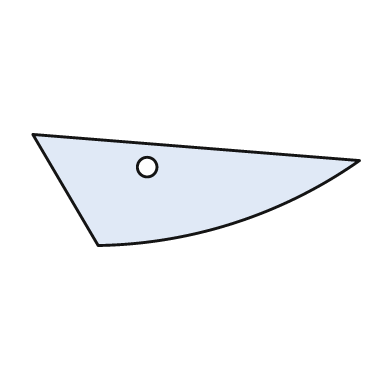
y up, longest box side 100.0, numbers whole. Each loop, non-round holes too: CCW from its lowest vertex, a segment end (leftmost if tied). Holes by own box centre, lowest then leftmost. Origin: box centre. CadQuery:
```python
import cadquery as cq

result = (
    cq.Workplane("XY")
    .moveTo(-30.0, -17.0)
    .threePointArc((12.0, -10.0), (50.0, 9.0))
    .lineTo(-50.0, 17.0)
    .close()
    .moveTo(-15.0, 7.0)
    .circle(3.0)
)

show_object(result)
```